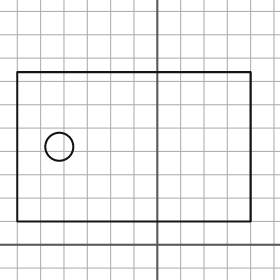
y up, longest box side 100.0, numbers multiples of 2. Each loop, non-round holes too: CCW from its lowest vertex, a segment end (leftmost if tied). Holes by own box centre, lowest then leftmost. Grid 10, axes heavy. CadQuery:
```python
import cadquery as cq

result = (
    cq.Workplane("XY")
    .moveTo(-60.0, 10.0)
    .lineTo(40.0, 10.0)
    .lineTo(40.0, 74.0)
    .lineTo(-60.0, 74.0)
    .close()
    .moveTo(-42.0, 42.0)
    .circle(6.0)
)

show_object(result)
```